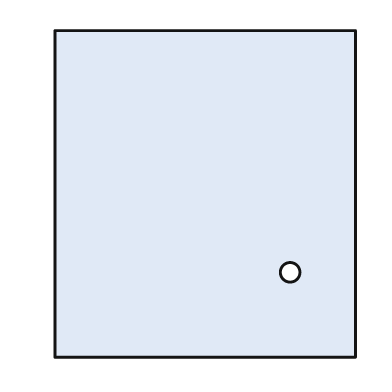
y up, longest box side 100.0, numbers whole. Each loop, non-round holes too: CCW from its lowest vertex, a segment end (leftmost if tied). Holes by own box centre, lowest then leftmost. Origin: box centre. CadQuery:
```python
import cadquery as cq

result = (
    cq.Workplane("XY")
    .moveTo(-46.0, -50.0)
    .lineTo(46.0, -50.0)
    .lineTo(46.0, 50.0)
    .lineTo(-46.0, 50.0)
    .close()
    .moveTo(26.0, -24.0)
    .circle(3.0)
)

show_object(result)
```